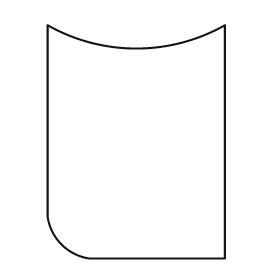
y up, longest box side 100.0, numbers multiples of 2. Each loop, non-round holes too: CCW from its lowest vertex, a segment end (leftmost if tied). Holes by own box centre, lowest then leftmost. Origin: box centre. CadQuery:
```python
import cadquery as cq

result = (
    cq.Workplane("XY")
    .moveTo(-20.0, -50.0)
    .lineTo(38.0, -50.0)
    .lineTo(38.0, 50.0)
    .threePointArc((0.0, 40.0), (-38.0, 50.0))
    .lineTo(-38.0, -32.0)
    .threePointArc((-32.0, -44.0), (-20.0, -50.0))
    .close()
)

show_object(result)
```